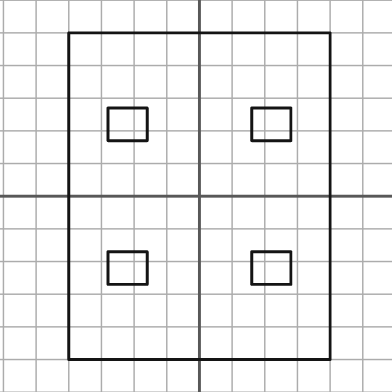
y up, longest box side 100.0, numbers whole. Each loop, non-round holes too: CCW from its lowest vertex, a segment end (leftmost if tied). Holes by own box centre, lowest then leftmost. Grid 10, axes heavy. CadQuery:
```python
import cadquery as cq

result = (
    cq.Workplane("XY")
    .moveTo(-40.0, -50.0)
    .lineTo(40.0, -50.0)
    .lineTo(40.0, 50.0)
    .lineTo(-40.0, 50.0)
    .close()
    .moveTo(-28.0, -27.0)
    .lineTo(-16.0, -27.0)
    .lineTo(-16.0, -17.0)
    .lineTo(-28.0, -17.0)
    .close()
    .moveTo(16.0, -27.0)
    .lineTo(28.0, -27.0)
    .lineTo(28.0, -17.0)
    .lineTo(16.0, -17.0)
    .close()
    .moveTo(-28.0, 17.0)
    .lineTo(-16.0, 17.0)
    .lineTo(-16.0, 27.0)
    .lineTo(-28.0, 27.0)
    .close()
    .moveTo(16.0, 17.0)
    .lineTo(28.0, 17.0)
    .lineTo(28.0, 27.0)
    .lineTo(16.0, 27.0)
    .close()
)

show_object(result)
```